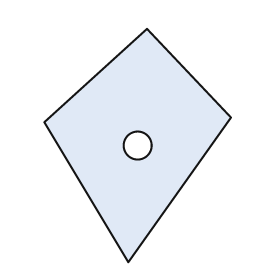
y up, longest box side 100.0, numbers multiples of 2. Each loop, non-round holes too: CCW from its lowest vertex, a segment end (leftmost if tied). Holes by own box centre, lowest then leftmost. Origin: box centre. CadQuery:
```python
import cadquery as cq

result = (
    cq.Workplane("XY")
    .moveTo(-4.0, -50.0)
    .lineTo(40.0, 12.0)
    .lineTo(4.0, 50.0)
    .lineTo(-40.0, 10.0)
    .close()
    .moveTo(0.0, 0.0)
    .circle(6.0)
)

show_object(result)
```